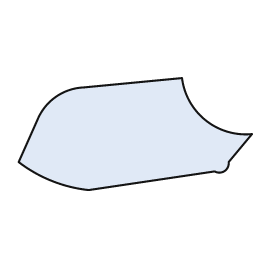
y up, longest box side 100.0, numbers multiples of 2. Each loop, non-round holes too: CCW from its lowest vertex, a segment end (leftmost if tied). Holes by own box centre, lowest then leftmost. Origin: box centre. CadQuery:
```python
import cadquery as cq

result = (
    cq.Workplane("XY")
    .moveTo(-20.0, -24.0)
    .lineTo(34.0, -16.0)
    .threePointArc((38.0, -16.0), (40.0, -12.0))
    .lineTo(50.0, 0.0)
    .threePointArc((30.0, 6.0), (20.0, 24.0))
    .lineTo(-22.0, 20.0)
    .threePointArc((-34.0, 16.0), (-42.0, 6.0))
    .lineTo(-50.0, -12.0)
    .threePointArc((-36.0, -20.0), (-20.0, -24.0))
    .close()
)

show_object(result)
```